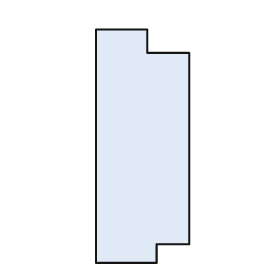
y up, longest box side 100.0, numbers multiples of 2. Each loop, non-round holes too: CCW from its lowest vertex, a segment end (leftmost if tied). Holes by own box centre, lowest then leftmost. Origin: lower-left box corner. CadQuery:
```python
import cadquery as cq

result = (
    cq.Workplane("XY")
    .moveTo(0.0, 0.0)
    .lineTo(26.0, 0.0)
    .lineTo(26.0, 8.0)
    .lineTo(40.0, 8.0)
    .lineTo(40.0, 90.0)
    .lineTo(22.0, 90.0)
    .lineTo(22.0, 100.0)
    .lineTo(0.0, 100.0)
    .close()
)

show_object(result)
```